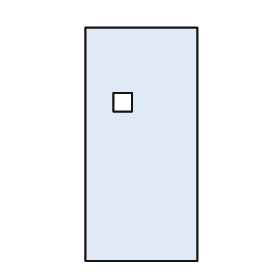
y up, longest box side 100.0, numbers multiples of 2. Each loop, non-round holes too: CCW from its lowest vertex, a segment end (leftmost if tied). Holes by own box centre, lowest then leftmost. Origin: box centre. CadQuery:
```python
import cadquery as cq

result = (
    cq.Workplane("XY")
    .moveTo(-24.0, -50.0)
    .lineTo(24.0, -50.0)
    .lineTo(24.0, 50.0)
    .lineTo(-24.0, 50.0)
    .close()
    .moveTo(-12.0, 14.0)
    .lineTo(-4.0, 14.0)
    .lineTo(-4.0, 22.0)
    .lineTo(-12.0, 22.0)
    .close()
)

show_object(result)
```